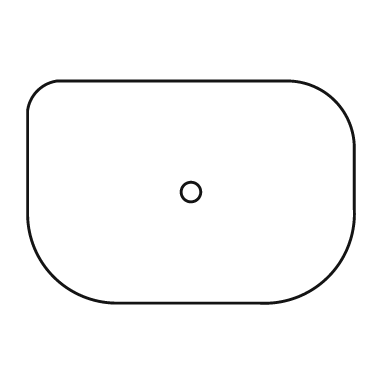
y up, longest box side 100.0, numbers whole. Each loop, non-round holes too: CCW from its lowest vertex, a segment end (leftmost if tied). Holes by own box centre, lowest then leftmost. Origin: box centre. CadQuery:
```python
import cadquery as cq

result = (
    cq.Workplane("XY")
    .moveTo(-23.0, -34.0)
    .lineTo(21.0, -34.0)
    .threePointArc((42.0, -26.0), (50.0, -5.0))
    .lineTo(50.0, 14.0)
    .threePointArc((44.0, 28.0), (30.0, 34.0))
    .lineTo(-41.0, 34.0)
    .threePointArc((-47.0, 31.0), (-50.0, 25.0))
    .lineTo(-50.0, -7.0)
    .threePointArc((-42.0, -26.0), (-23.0, -34.0))
    .close()
    .moveTo(0.0, 0.0)
    .circle(3.0)
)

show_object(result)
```